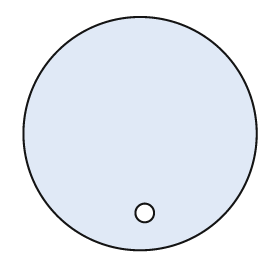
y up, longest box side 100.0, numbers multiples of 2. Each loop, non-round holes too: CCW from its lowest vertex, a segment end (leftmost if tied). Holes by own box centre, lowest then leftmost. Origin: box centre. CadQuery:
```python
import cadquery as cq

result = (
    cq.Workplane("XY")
    .moveTo(0.0, 0.0)
    .circle(50.0)
    .moveTo(2.0, -34.0)
    .circle(4.0)
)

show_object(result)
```